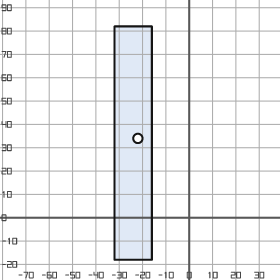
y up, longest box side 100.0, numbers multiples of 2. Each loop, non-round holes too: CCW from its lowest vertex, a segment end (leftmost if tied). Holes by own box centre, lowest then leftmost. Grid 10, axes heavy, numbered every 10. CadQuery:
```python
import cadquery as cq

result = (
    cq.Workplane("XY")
    .moveTo(-32.0, -18.0)
    .lineTo(-16.0, -18.0)
    .lineTo(-16.0, 82.0)
    .lineTo(-32.0, 82.0)
    .close()
    .moveTo(-22.0, 34.0)
    .circle(2.0)
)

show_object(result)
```